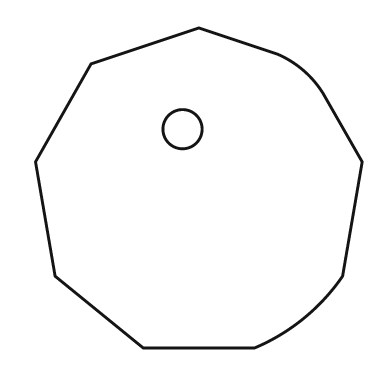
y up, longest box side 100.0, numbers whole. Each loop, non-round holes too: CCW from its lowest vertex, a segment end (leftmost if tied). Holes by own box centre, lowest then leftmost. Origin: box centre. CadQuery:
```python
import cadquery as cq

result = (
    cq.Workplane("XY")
    .moveTo(-17.0, -49.0)
    .lineTo(17.0, -49.0)
    .threePointArc((32.0, -40.0), (44.0, -27.0))
    .lineTo(50.0, 8.0)
    .lineTo(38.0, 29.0)
    .threePointArc((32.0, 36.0), (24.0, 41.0))
    .lineTo(0.0, 49.0)
    .lineTo(-33.0, 38.0)
    .lineTo(-50.0, 8.0)
    .lineTo(-44.0, -27.0)
    .close()
    .moveTo(-5.0, 18.0)
    .circle(6.0)
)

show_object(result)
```